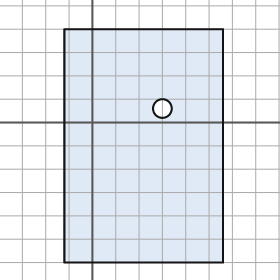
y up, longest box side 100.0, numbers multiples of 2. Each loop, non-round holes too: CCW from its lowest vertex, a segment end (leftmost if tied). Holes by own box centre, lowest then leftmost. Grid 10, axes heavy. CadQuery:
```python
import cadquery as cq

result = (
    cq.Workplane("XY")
    .moveTo(-12.0, -60.0)
    .lineTo(56.0, -60.0)
    .lineTo(56.0, 40.0)
    .lineTo(-12.0, 40.0)
    .close()
    .moveTo(30.0, 6.0)
    .circle(4.0)
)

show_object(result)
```